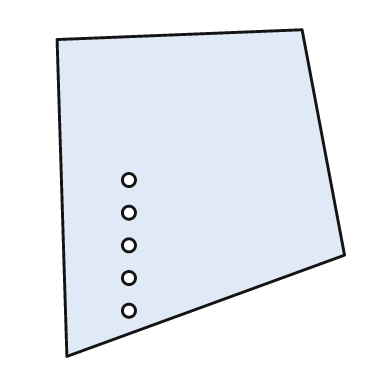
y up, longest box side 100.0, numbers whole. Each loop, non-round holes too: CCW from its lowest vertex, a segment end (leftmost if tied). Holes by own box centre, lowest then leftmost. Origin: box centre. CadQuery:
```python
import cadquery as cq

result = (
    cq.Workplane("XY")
    .moveTo(-41.0, -50.0)
    .lineTo(44.0, -19.0)
    .lineTo(31.0, 50.0)
    .lineTo(-44.0, 47.0)
    .close()
    .moveTo(-22.0, -36.0)
    .circle(2.0)
    .moveTo(-22.0, -26.0)
    .circle(2.0)
    .moveTo(-22.0, -16.0)
    .circle(2.0)
    .moveTo(-22.0, -6.0)
    .circle(2.0)
    .moveTo(-22.0, 4.0)
    .circle(2.0)
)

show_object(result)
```